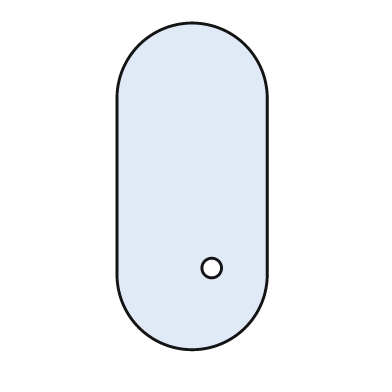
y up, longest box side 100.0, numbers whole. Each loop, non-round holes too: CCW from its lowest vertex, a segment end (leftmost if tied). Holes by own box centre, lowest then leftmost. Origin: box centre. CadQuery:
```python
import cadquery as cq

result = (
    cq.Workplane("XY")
    .moveTo(-23.0, -27.0)
    .threePointArc((0.0, -50.0), (23.0, -27.0))
    .lineTo(23.0, 27.0)
    .threePointArc((0.0, 50.0), (-23.0, 27.0))
    .close()
    .moveTo(6.0, -25.0)
    .circle(3.0)
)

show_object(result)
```